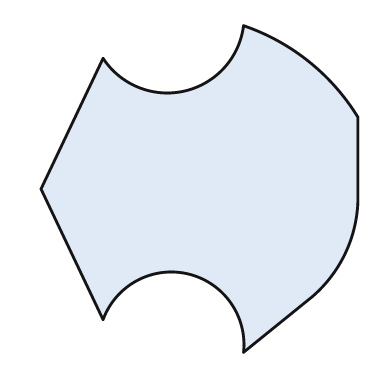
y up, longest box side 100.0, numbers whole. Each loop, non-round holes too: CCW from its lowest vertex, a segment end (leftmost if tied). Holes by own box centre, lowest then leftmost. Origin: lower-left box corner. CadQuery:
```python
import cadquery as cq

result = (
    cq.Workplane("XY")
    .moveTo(62.0, 0.0)
    .lineTo(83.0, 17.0)
    .threePointArc((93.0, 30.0), (97.0, 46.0))
    .lineTo(97.0, 72.0)
    .threePointArc((82.0, 89.0), (62.0, 100.0))
    .threePointArc((44.0, 80.0), (19.0, 90.0))
    .lineTo(0.0, 50.0)
    .lineTo(19.0, 10.0)
    .threePointArc((45.0, 24.0), (62.0, 0.0))
    .close()
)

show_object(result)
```